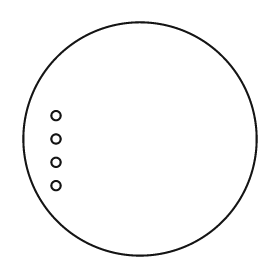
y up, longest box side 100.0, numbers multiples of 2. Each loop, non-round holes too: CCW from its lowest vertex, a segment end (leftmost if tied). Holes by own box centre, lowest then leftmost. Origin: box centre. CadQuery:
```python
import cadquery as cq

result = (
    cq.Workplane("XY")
    .moveTo(0.0, 0.0)
    .circle(50.0)
    .moveTo(-36.0, -20.0)
    .circle(2.0)
    .moveTo(-36.0, -10.0)
    .circle(2.0)
    .moveTo(-36.0, 0.0)
    .circle(2.0)
    .moveTo(-36.0, 10.0)
    .circle(2.0)
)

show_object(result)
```